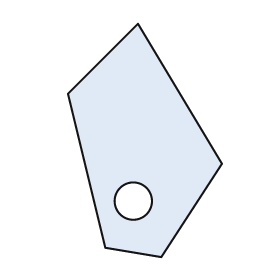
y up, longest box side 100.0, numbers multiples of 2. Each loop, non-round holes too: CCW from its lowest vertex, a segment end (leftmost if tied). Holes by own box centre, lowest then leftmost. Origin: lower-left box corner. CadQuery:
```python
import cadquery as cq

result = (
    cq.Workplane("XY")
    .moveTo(40.0, 0.0)
    .lineTo(66.0, 40.0)
    .lineTo(30.0, 100.0)
    .lineTo(0.0, 70.0)
    .lineTo(16.0, 4.0)
    .close()
    .moveTo(28.0, 24.0)
    .circle(8.0)
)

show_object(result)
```